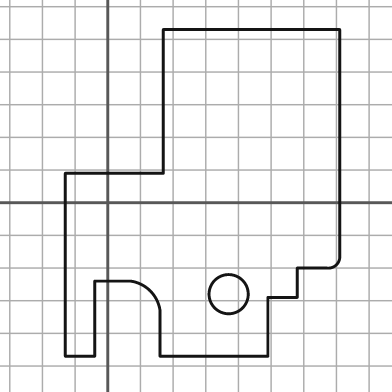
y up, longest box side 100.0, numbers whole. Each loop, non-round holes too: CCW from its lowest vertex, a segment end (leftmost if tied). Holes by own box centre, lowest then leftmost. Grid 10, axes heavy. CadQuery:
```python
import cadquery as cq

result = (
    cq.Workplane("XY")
    .moveTo(-13.0, -47.0)
    .lineTo(-4.0, -47.0)
    .lineTo(-4.0, -24.0)
    .lineTo(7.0, -24.0)
    .threePointArc((13.0, -27.0), (16.0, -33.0))
    .lineTo(16.0, -47.0)
    .lineTo(49.0, -47.0)
    .lineTo(49.0, -29.0)
    .lineTo(58.0, -29.0)
    .lineTo(58.0, -20.0)
    .lineTo(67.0, -20.0)
    .threePointArc((70.0, -19.0), (71.0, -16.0))
    .lineTo(71.0, 53.0)
    .lineTo(17.0, 53.0)
    .lineTo(17.0, 9.0)
    .lineTo(-13.0, 9.0)
    .close()
    .moveTo(37.0, -28.0)
    .circle(6.0)
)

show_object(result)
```